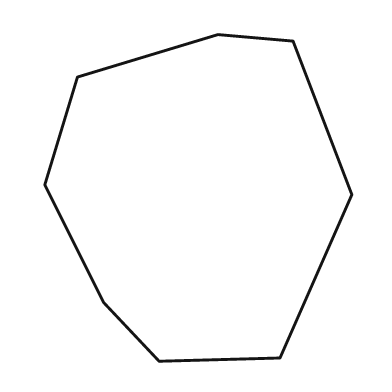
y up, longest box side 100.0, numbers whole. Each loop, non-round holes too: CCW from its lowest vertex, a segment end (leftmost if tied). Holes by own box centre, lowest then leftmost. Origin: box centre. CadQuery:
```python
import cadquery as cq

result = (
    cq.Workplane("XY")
    .moveTo(-12.0, -50.0)
    .lineTo(25.0, -49.0)
    .lineTo(47.0, 1.0)
    .lineTo(29.0, 48.0)
    .lineTo(6.0, 50.0)
    .lineTo(-37.0, 37.0)
    .lineTo(-47.0, 4.0)
    .lineTo(-29.0, -32.0)
    .close()
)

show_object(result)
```